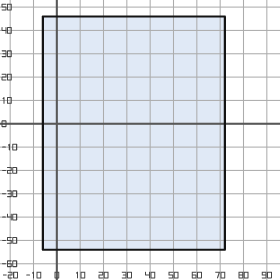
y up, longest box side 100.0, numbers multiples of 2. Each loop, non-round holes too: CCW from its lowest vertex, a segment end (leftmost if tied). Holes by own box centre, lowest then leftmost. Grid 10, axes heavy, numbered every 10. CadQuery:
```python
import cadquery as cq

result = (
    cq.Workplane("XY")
    .moveTo(-6.0, -54.0)
    .lineTo(72.0, -54.0)
    .lineTo(72.0, 46.0)
    .lineTo(-6.0, 46.0)
    .close()
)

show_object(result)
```